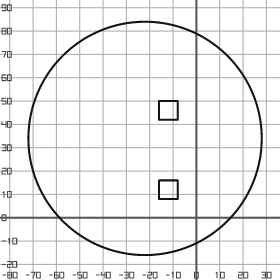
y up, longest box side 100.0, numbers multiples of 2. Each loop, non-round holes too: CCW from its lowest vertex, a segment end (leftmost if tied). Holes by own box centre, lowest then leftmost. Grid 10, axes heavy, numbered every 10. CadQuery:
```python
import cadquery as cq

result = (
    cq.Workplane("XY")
    .moveTo(-22.0, 34.0)
    .circle(50.0)
    .moveTo(-16.0, 8.0)
    .lineTo(-8.0, 8.0)
    .lineTo(-8.0, 16.0)
    .lineTo(-16.0, 16.0)
    .close()
    .moveTo(-16.0, 42.0)
    .lineTo(-8.0, 42.0)
    .lineTo(-8.0, 50.0)
    .lineTo(-16.0, 50.0)
    .close()
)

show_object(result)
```